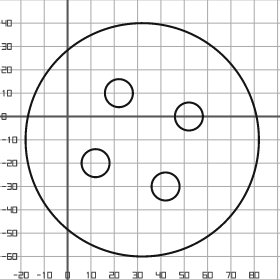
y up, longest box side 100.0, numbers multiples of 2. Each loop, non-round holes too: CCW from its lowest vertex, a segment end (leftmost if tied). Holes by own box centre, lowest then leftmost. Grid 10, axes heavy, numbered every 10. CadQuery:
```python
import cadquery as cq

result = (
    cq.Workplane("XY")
    .moveTo(32.0, -10.0)
    .circle(50.0)
    .moveTo(42.0, -30.0)
    .circle(6.0)
    .moveTo(12.0, -20.0)
    .circle(6.0)
    .moveTo(52.0, 0.0)
    .circle(6.0)
    .moveTo(22.0, 10.0)
    .circle(6.0)
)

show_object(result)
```